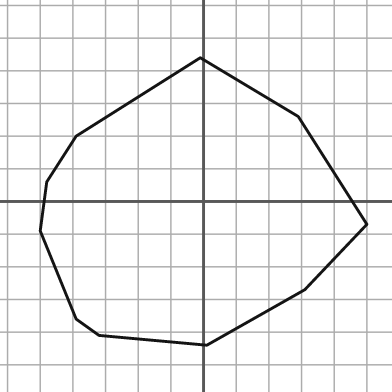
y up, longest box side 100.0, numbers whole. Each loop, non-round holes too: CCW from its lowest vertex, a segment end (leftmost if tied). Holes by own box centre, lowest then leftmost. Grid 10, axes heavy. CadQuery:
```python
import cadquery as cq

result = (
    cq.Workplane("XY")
    .moveTo(1.0, -44.0)
    .lineTo(31.0, -27.0)
    .lineTo(50.0, -7.0)
    .lineTo(29.0, 26.0)
    .lineTo(-1.0, 44.0)
    .lineTo(-39.0, 20.0)
    .lineTo(-48.0, 6.0)
    .lineTo(-50.0, -9.0)
    .lineTo(-39.0, -36.0)
    .lineTo(-32.0, -41.0)
    .close()
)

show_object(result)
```